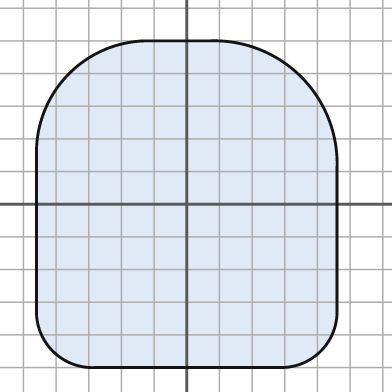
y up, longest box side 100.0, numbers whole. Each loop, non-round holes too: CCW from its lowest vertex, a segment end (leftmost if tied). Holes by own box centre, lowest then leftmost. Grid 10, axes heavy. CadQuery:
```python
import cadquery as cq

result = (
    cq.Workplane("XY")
    .moveTo(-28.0, -50.0)
    .lineTo(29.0, -50.0)
    .threePointArc((41.0, -45.0), (46.0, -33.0))
    .lineTo(46.0, 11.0)
    .threePointArc((35.0, 39.0), (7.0, 50.0))
    .lineTo(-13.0, 50.0)
    .threePointArc((-36.0, 40.0), (-46.0, 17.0))
    .lineTo(-46.0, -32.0)
    .threePointArc((-41.0, -45.0), (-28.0, -50.0))
    .close()
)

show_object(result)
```